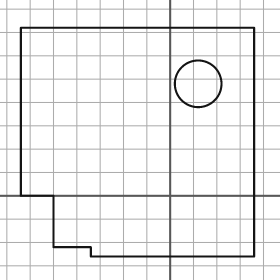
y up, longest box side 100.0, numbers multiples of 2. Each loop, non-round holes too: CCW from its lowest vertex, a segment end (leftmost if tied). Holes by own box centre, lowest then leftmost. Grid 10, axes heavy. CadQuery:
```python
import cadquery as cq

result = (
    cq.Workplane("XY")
    .moveTo(-34.0, -26.0)
    .lineTo(36.0, -26.0)
    .lineTo(36.0, 72.0)
    .lineTo(-64.0, 72.0)
    .lineTo(-64.0, 0.0)
    .lineTo(-50.0, 0.0)
    .lineTo(-50.0, -22.0)
    .lineTo(-34.0, -22.0)
    .close()
    .moveTo(12.0, 48.0)
    .circle(10.0)
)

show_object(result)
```